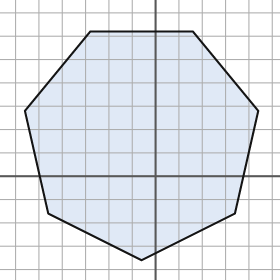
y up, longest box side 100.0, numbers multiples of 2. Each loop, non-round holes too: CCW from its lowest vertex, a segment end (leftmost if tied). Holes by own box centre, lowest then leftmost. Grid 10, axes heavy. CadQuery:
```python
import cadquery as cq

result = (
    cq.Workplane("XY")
    .moveTo(-6.0, -36.0)
    .lineTo(34.0, -16.0)
    .lineTo(44.0, 28.0)
    .lineTo(16.0, 62.0)
    .lineTo(-28.0, 62.0)
    .lineTo(-56.0, 28.0)
    .lineTo(-46.0, -16.0)
    .close()
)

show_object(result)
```